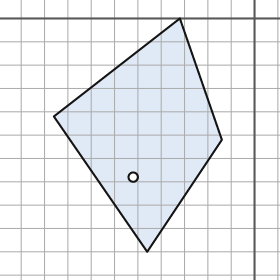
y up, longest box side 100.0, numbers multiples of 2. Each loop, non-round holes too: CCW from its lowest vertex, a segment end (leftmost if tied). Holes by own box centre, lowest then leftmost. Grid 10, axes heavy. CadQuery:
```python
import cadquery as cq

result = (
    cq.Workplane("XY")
    .moveTo(-46.0, -100.0)
    .lineTo(-14.0, -52.0)
    .lineTo(-32.0, 0.0)
    .lineTo(-86.0, -42.0)
    .close()
    .moveTo(-52.0, -68.0)
    .circle(2.0)
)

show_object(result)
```